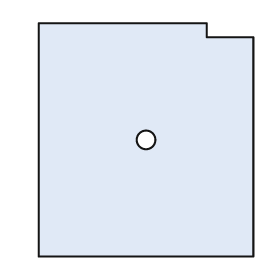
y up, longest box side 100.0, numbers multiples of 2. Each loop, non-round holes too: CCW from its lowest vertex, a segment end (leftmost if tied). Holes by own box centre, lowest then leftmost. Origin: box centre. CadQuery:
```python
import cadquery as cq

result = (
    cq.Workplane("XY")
    .moveTo(-46.0, -50.0)
    .lineTo(46.0, -50.0)
    .lineTo(46.0, 44.0)
    .lineTo(26.0, 44.0)
    .lineTo(26.0, 50.0)
    .lineTo(-46.0, 50.0)
    .close()
    .moveTo(0.0, 0.0)
    .circle(4.0)
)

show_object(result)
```